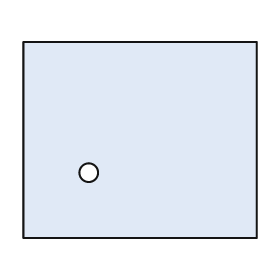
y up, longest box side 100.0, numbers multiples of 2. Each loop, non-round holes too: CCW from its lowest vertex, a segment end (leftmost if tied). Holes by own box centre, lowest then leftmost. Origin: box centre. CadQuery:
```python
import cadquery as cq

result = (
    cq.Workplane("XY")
    .moveTo(-50.0, -42.0)
    .lineTo(50.0, -42.0)
    .lineTo(50.0, 42.0)
    .lineTo(-50.0, 42.0)
    .close()
    .moveTo(-22.0, -14.0)
    .circle(4.0)
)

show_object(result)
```